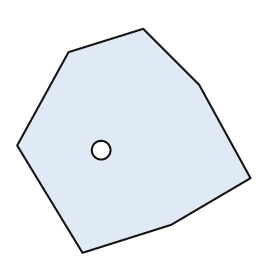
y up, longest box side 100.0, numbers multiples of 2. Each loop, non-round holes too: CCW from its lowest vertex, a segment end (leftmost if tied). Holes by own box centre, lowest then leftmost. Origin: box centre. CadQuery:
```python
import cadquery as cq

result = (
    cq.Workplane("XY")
    .moveTo(-22.0, -48.0)
    .lineTo(16.0, -36.0)
    .lineTo(50.0, -16.0)
    .lineTo(28.0, 24.0)
    .lineTo(4.0, 48.0)
    .lineTo(-28.0, 38.0)
    .lineTo(-50.0, -2.0)
    .close()
    .moveTo(-14.0, -4.0)
    .circle(4.0)
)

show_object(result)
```